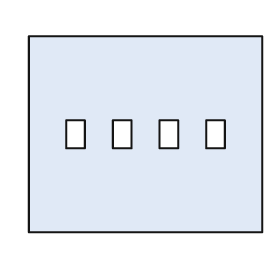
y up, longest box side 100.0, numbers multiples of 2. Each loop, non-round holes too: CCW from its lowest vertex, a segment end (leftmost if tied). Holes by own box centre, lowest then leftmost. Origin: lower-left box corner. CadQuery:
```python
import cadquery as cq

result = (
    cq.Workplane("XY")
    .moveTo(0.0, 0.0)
    .lineTo(100.0, 0.0)
    .lineTo(100.0, 84.0)
    .lineTo(0.0, 84.0)
    .close()
    .moveTo(16.0, 36.0)
    .lineTo(24.0, 36.0)
    .lineTo(24.0, 48.0)
    .lineTo(16.0, 48.0)
    .close()
    .moveTo(36.0, 36.0)
    .lineTo(44.0, 36.0)
    .lineTo(44.0, 48.0)
    .lineTo(36.0, 48.0)
    .close()
    .moveTo(56.0, 36.0)
    .lineTo(64.0, 36.0)
    .lineTo(64.0, 48.0)
    .lineTo(56.0, 48.0)
    .close()
    .moveTo(76.0, 36.0)
    .lineTo(84.0, 36.0)
    .lineTo(84.0, 48.0)
    .lineTo(76.0, 48.0)
    .close()
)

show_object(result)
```